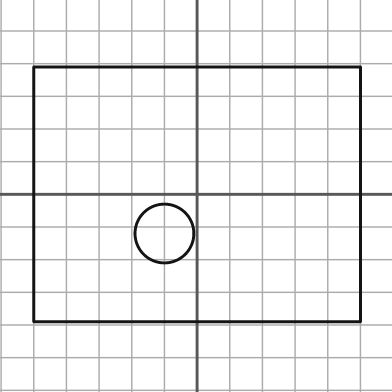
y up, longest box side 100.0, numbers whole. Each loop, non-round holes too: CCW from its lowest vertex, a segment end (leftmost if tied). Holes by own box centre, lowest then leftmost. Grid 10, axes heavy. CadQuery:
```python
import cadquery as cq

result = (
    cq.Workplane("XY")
    .moveTo(-50.0, -39.0)
    .lineTo(50.0, -39.0)
    .lineTo(50.0, 39.0)
    .lineTo(-50.0, 39.0)
    .close()
    .moveTo(-10.0, -12.0)
    .circle(9.0)
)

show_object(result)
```